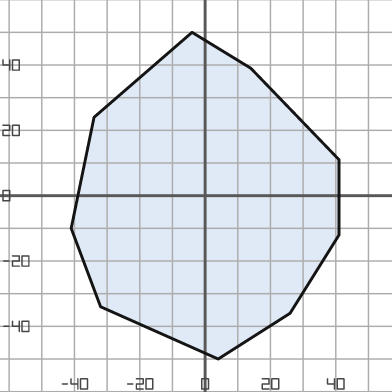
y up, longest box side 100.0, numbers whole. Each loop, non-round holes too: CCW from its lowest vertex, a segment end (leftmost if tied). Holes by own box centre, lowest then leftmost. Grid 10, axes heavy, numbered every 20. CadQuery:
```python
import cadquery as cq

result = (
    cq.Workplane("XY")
    .moveTo(4.0, -50.0)
    .lineTo(26.0, -36.0)
    .lineTo(41.0, -12.0)
    .lineTo(41.0, 11.0)
    .lineTo(14.0, 39.0)
    .lineTo(-4.0, 50.0)
    .lineTo(-34.0, 24.0)
    .lineTo(-41.0, -10.0)
    .lineTo(-32.0, -34.0)
    .close()
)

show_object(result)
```